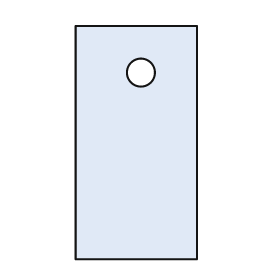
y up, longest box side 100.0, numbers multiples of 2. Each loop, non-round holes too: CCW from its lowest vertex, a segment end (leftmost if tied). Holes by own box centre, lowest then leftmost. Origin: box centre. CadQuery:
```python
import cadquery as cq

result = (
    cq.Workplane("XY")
    .moveTo(-26.0, -50.0)
    .lineTo(26.0, -50.0)
    .lineTo(26.0, 50.0)
    .lineTo(-26.0, 50.0)
    .close()
    .moveTo(2.0, 30.0)
    .circle(6.0)
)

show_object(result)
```